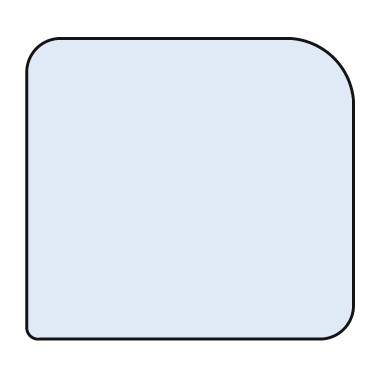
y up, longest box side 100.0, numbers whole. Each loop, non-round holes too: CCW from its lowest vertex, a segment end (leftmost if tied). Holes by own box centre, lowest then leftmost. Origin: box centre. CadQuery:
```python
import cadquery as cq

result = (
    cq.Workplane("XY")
    .moveTo(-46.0, -46.0)
    .lineTo(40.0, -46.0)
    .threePointArc((47.0, -43.0), (50.0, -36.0))
    .lineTo(50.0, 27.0)
    .threePointArc((44.0, 40.0), (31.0, 46.0))
    .lineTo(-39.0, 46.0)
    .threePointArc((-47.0, 43.0), (-50.0, 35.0))
    .lineTo(-50.0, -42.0)
    .threePointArc((-49.0, -45.0), (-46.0, -46.0))
    .close()
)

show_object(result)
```